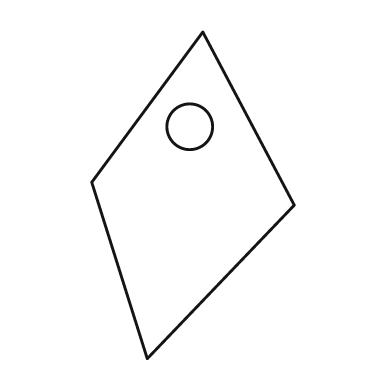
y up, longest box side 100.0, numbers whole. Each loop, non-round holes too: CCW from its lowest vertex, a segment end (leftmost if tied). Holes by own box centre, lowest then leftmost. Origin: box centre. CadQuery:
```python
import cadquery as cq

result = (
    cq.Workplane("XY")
    .moveTo(-14.0, -50.0)
    .lineTo(31.0, -3.0)
    .lineTo(3.0, 50.0)
    .lineTo(-31.0, 4.0)
    .close()
    .moveTo(-1.0, 21.0)
    .circle(7.0)
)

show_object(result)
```